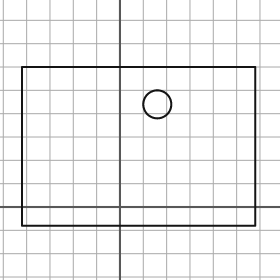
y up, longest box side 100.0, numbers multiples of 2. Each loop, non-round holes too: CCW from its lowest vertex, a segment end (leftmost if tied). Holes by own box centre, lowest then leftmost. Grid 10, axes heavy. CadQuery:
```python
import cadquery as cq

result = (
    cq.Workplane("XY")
    .moveTo(-42.0, -8.0)
    .lineTo(58.0, -8.0)
    .lineTo(58.0, 60.0)
    .lineTo(-42.0, 60.0)
    .close()
    .moveTo(16.0, 44.0)
    .circle(6.0)
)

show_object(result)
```